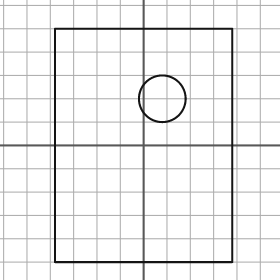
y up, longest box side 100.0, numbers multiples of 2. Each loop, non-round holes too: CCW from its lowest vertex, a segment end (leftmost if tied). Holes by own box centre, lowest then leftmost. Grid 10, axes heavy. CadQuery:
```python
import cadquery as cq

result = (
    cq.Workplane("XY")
    .moveTo(-38.0, -50.0)
    .lineTo(38.0, -50.0)
    .lineTo(38.0, 50.0)
    .lineTo(-38.0, 50.0)
    .close()
    .moveTo(8.0, 20.0)
    .circle(10.0)
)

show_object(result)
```